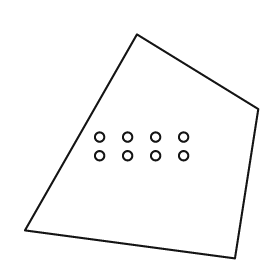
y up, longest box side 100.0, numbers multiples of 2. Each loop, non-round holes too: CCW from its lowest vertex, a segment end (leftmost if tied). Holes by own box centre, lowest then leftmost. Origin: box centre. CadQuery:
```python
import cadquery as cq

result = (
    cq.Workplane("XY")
    .moveTo(40.0, -48.0)
    .lineTo(50.0, 16.0)
    .lineTo(-2.0, 48.0)
    .lineTo(-50.0, -36.0)
    .close()
    .moveTo(-18.0, -4.0)
    .circle(2.0)
    .moveTo(-6.0, -4.0)
    .circle(2.0)
    .moveTo(6.0, -4.0)
    .circle(2.0)
    .moveTo(18.0, -4.0)
    .circle(2.0)
    .moveTo(-18.0, 4.0)
    .circle(2.0)
    .moveTo(-6.0, 4.0)
    .circle(2.0)
    .moveTo(6.0, 4.0)
    .circle(2.0)
    .moveTo(18.0, 4.0)
    .circle(2.0)
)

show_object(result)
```